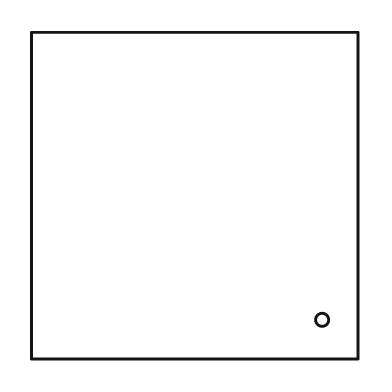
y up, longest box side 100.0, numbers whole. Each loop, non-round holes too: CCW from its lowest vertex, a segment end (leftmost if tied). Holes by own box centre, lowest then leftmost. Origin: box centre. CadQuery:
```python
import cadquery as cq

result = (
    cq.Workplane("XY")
    .moveTo(-50.0, -50.0)
    .lineTo(50.0, -50.0)
    .lineTo(50.0, 50.0)
    .lineTo(-50.0, 50.0)
    .close()
    .moveTo(39.0, -38.0)
    .circle(2.0)
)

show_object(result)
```